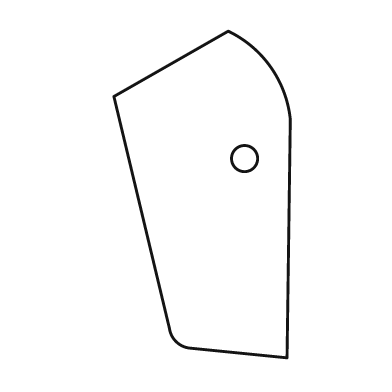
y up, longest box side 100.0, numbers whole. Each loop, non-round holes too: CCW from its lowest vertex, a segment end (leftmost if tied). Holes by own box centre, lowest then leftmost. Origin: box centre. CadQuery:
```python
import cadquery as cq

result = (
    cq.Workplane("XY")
    .moveTo(26.0, -50.0)
    .lineTo(27.0, 23.0)
    .threePointArc((21.0, 39.0), (8.0, 50.0))
    .lineTo(-27.0, 30.0)
    .lineTo(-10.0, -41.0)
    .threePointArc((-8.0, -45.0), (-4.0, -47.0))
    .close()
    .moveTo(13.0, 11.0)
    .circle(4.0)
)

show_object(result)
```